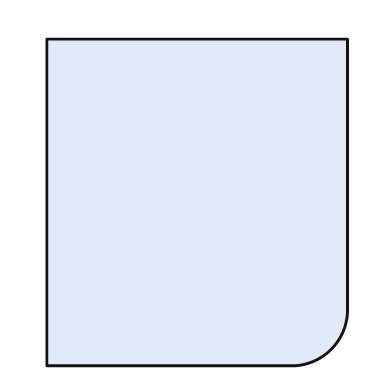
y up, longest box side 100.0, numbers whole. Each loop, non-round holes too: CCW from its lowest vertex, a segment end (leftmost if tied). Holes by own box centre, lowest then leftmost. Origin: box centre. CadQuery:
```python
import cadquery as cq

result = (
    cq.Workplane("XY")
    .moveTo(-46.0, -50.0)
    .lineTo(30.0, -50.0)
    .threePointArc((41.0, -45.0), (46.0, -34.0))
    .lineTo(46.0, 50.0)
    .lineTo(-46.0, 50.0)
    .close()
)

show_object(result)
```